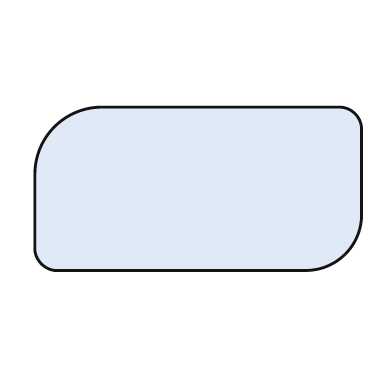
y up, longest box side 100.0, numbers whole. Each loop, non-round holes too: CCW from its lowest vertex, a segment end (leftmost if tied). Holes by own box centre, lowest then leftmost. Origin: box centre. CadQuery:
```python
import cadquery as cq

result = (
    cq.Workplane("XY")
    .moveTo(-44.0, -25.0)
    .lineTo(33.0, -25.0)
    .threePointArc((45.0, -20.0), (50.0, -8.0))
    .lineTo(50.0, 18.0)
    .threePointArc((48.0, 23.0), (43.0, 25.0))
    .lineTo(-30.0, 25.0)
    .threePointArc((-44.0, 19.0), (-50.0, 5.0))
    .lineTo(-50.0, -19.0)
    .threePointArc((-48.0, -23.0), (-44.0, -25.0))
    .close()
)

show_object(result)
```